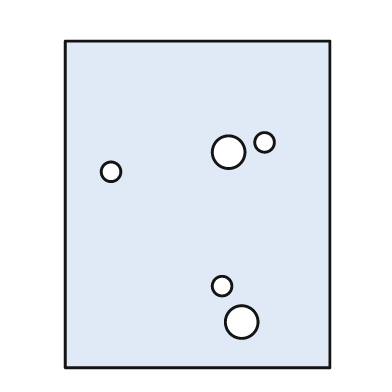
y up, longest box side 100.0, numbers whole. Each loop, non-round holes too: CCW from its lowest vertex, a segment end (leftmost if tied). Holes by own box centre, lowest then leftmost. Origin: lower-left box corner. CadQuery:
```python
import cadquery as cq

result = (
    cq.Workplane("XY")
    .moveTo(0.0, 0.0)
    .lineTo(81.0, 0.0)
    .lineTo(81.0, 100.0)
    .lineTo(0.0, 100.0)
    .close()
    .moveTo(54.0, 14.0)
    .circle(5.0)
    .moveTo(48.0, 25.0)
    .circle(3.0)
    .moveTo(14.0, 60.0)
    .circle(3.0)
    .moveTo(50.0, 66.0)
    .circle(5.0)
    .moveTo(61.0, 69.0)
    .circle(3.0)
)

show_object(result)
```